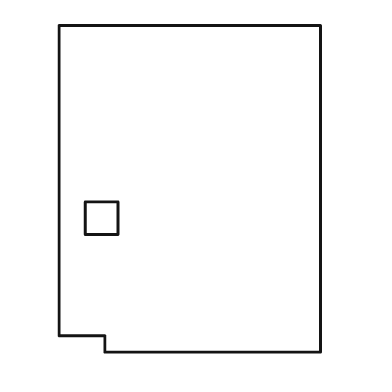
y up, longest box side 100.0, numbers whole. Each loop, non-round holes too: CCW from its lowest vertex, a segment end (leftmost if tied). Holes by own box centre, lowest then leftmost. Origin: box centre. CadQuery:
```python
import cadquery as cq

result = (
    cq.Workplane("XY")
    .moveTo(-26.0, -50.0)
    .lineTo(40.0, -50.0)
    .lineTo(40.0, 50.0)
    .lineTo(-40.0, 50.0)
    .lineTo(-40.0, -45.0)
    .lineTo(-26.0, -45.0)
    .close()
    .moveTo(-32.0, -14.0)
    .lineTo(-22.0, -14.0)
    .lineTo(-22.0, -4.0)
    .lineTo(-32.0, -4.0)
    .close()
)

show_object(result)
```